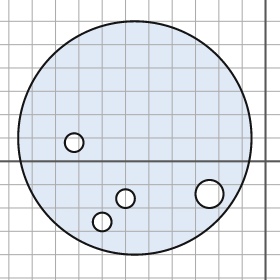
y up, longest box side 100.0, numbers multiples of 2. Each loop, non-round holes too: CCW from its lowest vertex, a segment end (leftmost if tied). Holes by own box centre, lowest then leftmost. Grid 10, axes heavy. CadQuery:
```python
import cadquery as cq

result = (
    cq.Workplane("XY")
    .moveTo(-56.0, 10.0)
    .circle(50.0)
    .moveTo(-70.0, -26.0)
    .circle(4.0)
    .moveTo(-60.0, -16.0)
    .circle(4.0)
    .moveTo(-24.0, -14.0)
    .circle(6.0)
    .moveTo(-82.0, 8.0)
    .circle(4.0)
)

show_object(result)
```